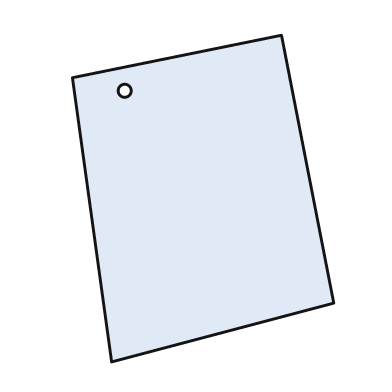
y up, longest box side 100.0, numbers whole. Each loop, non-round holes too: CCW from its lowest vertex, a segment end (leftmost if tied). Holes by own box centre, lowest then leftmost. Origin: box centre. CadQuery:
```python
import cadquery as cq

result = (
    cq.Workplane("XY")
    .moveTo(-28.0, -50.0)
    .lineTo(40.0, -32.0)
    .lineTo(24.0, 50.0)
    .lineTo(-40.0, 37.0)
    .close()
    .moveTo(-24.0, 33.0)
    .circle(2.0)
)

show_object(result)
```